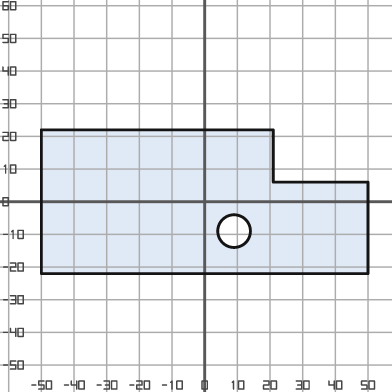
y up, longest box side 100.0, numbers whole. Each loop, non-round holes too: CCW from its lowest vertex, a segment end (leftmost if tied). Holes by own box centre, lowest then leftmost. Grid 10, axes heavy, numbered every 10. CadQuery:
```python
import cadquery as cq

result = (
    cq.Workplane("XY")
    .moveTo(-50.0, -22.0)
    .lineTo(50.0, -22.0)
    .lineTo(50.0, 6.0)
    .lineTo(21.0, 6.0)
    .lineTo(21.0, 22.0)
    .lineTo(-50.0, 22.0)
    .close()
    .moveTo(9.0, -9.0)
    .circle(5.0)
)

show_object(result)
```